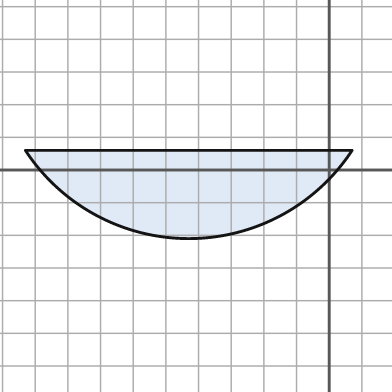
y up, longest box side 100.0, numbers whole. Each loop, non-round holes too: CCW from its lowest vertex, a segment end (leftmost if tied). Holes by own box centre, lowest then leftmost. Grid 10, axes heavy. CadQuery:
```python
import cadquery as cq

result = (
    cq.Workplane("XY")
    .moveTo(-93.0, 6.0)
    .threePointArc((-43.0, -21.0), (7.0, 6.0))
    .close()
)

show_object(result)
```